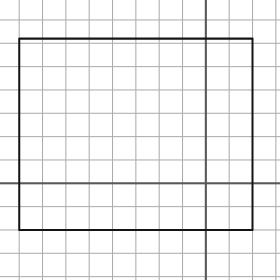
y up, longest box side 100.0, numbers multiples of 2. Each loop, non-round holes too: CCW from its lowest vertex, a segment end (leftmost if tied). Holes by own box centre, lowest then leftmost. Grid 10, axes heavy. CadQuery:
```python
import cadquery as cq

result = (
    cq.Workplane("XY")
    .moveTo(-80.0, -20.0)
    .lineTo(20.0, -20.0)
    .lineTo(20.0, 62.0)
    .lineTo(-80.0, 62.0)
    .close()
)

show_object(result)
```